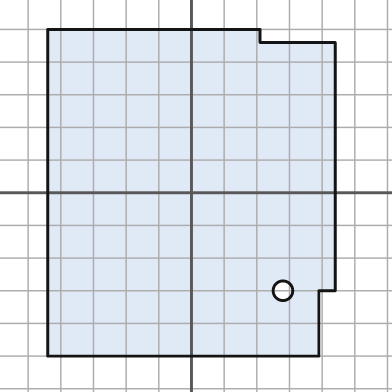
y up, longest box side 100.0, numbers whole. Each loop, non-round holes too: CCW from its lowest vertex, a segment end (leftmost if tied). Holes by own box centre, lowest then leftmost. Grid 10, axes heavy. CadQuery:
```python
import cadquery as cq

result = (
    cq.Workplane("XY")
    .moveTo(-44.0, -50.0)
    .lineTo(39.0, -50.0)
    .lineTo(39.0, -30.0)
    .lineTo(44.0, -30.0)
    .lineTo(44.0, 46.0)
    .lineTo(21.0, 46.0)
    .lineTo(21.0, 50.0)
    .lineTo(-44.0, 50.0)
    .close()
    .moveTo(28.0, -30.0)
    .circle(3.0)
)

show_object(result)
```